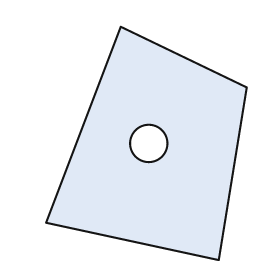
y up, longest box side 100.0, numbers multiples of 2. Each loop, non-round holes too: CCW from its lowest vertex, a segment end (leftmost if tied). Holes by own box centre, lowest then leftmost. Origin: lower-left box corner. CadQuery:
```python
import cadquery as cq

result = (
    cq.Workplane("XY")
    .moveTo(74.0, 0.0)
    .lineTo(86.0, 74.0)
    .lineTo(32.0, 100.0)
    .lineTo(0.0, 16.0)
    .close()
    .moveTo(44.0, 50.0)
    .circle(8.0)
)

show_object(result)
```